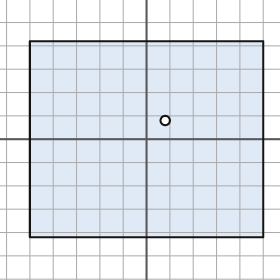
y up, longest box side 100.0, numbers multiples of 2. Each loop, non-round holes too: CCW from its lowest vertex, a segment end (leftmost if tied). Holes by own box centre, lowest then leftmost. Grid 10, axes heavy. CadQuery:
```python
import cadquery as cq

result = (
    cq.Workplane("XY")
    .moveTo(-50.0, -42.0)
    .lineTo(50.0, -42.0)
    .lineTo(50.0, 42.0)
    .lineTo(-50.0, 42.0)
    .close()
    .moveTo(8.0, 8.0)
    .circle(2.0)
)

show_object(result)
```